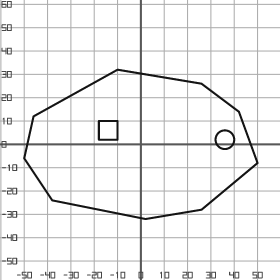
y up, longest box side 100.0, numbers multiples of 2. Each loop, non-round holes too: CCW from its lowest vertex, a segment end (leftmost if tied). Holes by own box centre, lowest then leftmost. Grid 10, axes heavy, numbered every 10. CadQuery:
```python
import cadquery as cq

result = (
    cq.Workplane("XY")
    .moveTo(2.0, -32.0)
    .lineTo(26.0, -28.0)
    .lineTo(50.0, -8.0)
    .lineTo(42.0, 14.0)
    .lineTo(26.0, 26.0)
    .lineTo(-10.0, 32.0)
    .lineTo(-46.0, 12.0)
    .lineTo(-50.0, -6.0)
    .lineTo(-38.0, -24.0)
    .close()
    .moveTo(36.0, 2.0)
    .circle(4.0)
    .moveTo(-18.0, 2.0)
    .lineTo(-10.0, 2.0)
    .lineTo(-10.0, 10.0)
    .lineTo(-18.0, 10.0)
    .close()
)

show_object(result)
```